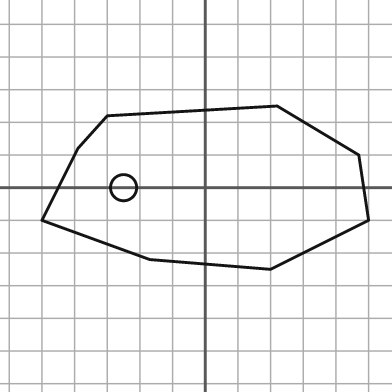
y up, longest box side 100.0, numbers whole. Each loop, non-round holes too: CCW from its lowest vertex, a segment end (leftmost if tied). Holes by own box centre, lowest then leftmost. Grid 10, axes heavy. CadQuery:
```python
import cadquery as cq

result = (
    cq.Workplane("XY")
    .moveTo(20.0, -25.0)
    .lineTo(50.0, -10.0)
    .lineTo(47.0, 10.0)
    .lineTo(22.0, 25.0)
    .lineTo(-30.0, 22.0)
    .lineTo(-39.0, 12.0)
    .lineTo(-50.0, -10.0)
    .lineTo(-17.0, -22.0)
    .close()
    .moveTo(-25.0, 0.0)
    .circle(4.0)
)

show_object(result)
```